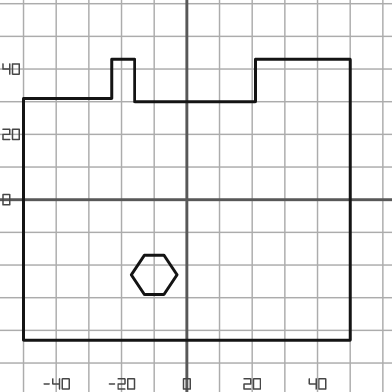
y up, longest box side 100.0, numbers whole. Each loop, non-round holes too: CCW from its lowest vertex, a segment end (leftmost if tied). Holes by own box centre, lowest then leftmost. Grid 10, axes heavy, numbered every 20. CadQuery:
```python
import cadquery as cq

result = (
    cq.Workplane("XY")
    .moveTo(-50.0, -43.0)
    .lineTo(50.0, -43.0)
    .lineTo(50.0, 43.0)
    .lineTo(21.0, 43.0)
    .lineTo(21.0, 30.0)
    .lineTo(-16.0, 30.0)
    .lineTo(-16.0, 43.0)
    .lineTo(-23.0, 43.0)
    .lineTo(-23.0, 31.0)
    .lineTo(-50.0, 31.0)
    .close()
    .moveTo(-13.0, -29.0)
    .lineTo(-7.0, -29.0)
    .lineTo(-3.0, -23.0)
    .lineTo(-7.0, -17.0)
    .lineTo(-13.0, -17.0)
    .lineTo(-17.0, -23.0)
    .close()
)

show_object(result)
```